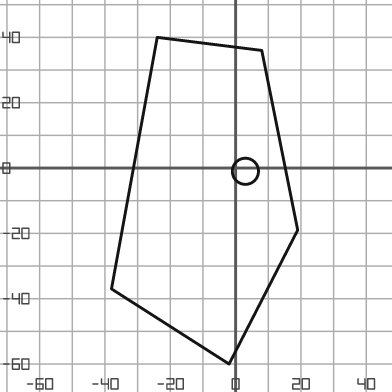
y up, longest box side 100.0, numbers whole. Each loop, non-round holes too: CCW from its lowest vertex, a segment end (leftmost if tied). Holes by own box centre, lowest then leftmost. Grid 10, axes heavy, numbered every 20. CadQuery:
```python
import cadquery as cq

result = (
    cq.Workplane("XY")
    .moveTo(-2.0, -60.0)
    .lineTo(19.0, -19.0)
    .lineTo(8.0, 36.0)
    .lineTo(-24.0, 40.0)
    .lineTo(-38.0, -37.0)
    .close()
    .moveTo(3.0, -1.0)
    .circle(4.0)
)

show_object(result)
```